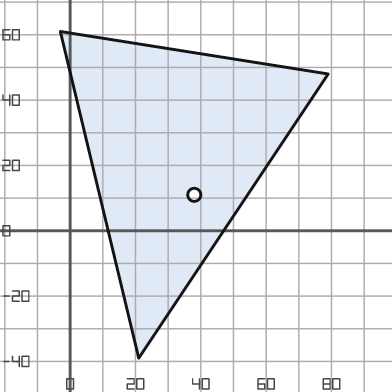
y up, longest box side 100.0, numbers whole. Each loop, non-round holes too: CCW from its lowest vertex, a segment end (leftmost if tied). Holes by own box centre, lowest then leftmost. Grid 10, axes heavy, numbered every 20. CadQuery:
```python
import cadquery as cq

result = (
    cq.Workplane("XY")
    .moveTo(21.0, -39.0)
    .lineTo(79.0, 48.0)
    .lineTo(-3.0, 61.0)
    .close()
    .moveTo(38.0, 11.0)
    .circle(2.0)
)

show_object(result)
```